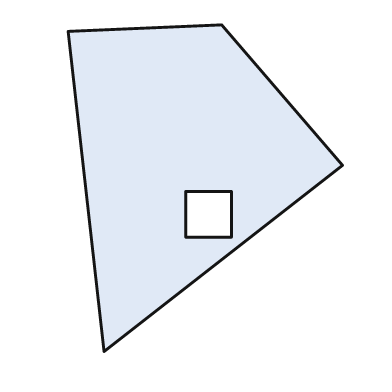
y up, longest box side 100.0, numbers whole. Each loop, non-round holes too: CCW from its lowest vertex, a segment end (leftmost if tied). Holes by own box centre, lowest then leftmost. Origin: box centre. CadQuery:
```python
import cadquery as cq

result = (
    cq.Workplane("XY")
    .moveTo(-31.0, -50.0)
    .lineTo(42.0, 7.0)
    .lineTo(5.0, 50.0)
    .lineTo(-42.0, 48.0)
    .close()
    .moveTo(-6.0, -15.0)
    .lineTo(8.0, -15.0)
    .lineTo(8.0, -1.0)
    .lineTo(-6.0, -1.0)
    .close()
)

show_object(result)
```